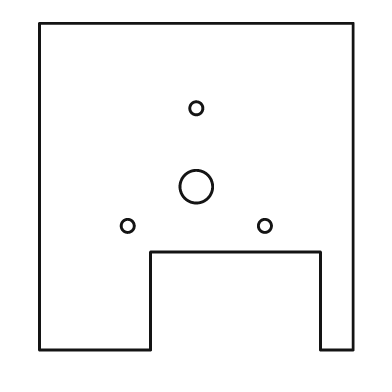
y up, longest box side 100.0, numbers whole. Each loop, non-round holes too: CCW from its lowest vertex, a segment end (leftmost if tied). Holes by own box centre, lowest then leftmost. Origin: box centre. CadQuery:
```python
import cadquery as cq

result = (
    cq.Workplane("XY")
    .moveTo(-48.0, -50.0)
    .lineTo(-14.0, -50.0)
    .lineTo(-14.0, -20.0)
    .lineTo(38.0, -20.0)
    .lineTo(38.0, -50.0)
    .lineTo(48.0, -50.0)
    .lineTo(48.0, 50.0)
    .lineTo(-48.0, 50.0)
    .close()
    .moveTo(-21.0, -12.0)
    .circle(2.0)
    .moveTo(21.0, -12.0)
    .circle(2.0)
    .moveTo(0.0, 0.0)
    .circle(5.0)
    .moveTo(0.0, 24.0)
    .circle(2.0)
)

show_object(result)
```